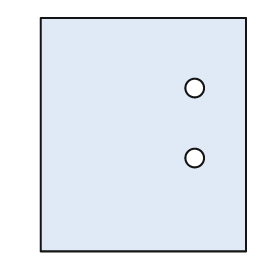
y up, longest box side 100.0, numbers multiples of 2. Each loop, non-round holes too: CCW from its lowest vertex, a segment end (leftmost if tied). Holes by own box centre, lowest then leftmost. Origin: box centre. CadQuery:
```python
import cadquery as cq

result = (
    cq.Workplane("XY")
    .moveTo(-44.0, -50.0)
    .lineTo(44.0, -50.0)
    .lineTo(44.0, 50.0)
    .lineTo(-44.0, 50.0)
    .close()
    .moveTo(22.0, -10.0)
    .circle(4.0)
    .moveTo(22.0, 20.0)
    .circle(4.0)
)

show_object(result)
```